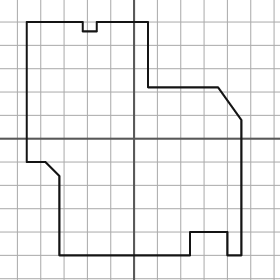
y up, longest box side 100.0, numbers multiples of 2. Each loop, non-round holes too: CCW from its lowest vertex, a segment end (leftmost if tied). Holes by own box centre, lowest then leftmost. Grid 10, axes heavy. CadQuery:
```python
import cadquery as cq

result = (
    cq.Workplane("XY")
    .moveTo(-32.0, -50.0)
    .lineTo(24.0, -50.0)
    .lineTo(24.0, -40.0)
    .lineTo(40.0, -40.0)
    .lineTo(40.0, -50.0)
    .lineTo(46.0, -50.0)
    .lineTo(46.0, 8.0)
    .lineTo(36.0, 22.0)
    .lineTo(6.0, 22.0)
    .lineTo(6.0, 50.0)
    .lineTo(-16.0, 50.0)
    .lineTo(-16.0, 46.0)
    .lineTo(-22.0, 46.0)
    .lineTo(-22.0, 50.0)
    .lineTo(-46.0, 50.0)
    .lineTo(-46.0, -10.0)
    .lineTo(-38.0, -10.0)
    .lineTo(-32.0, -16.0)
    .close()
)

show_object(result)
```